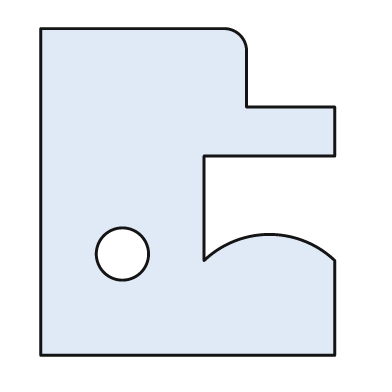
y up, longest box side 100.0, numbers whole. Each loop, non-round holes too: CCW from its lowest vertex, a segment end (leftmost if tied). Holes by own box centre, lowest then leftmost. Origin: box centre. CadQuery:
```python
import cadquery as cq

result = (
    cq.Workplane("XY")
    .moveTo(-45.0, -50.0)
    .lineTo(45.0, -50.0)
    .lineTo(45.0, -21.0)
    .threePointArc((25.0, -13.0), (5.0, -21.0))
    .lineTo(5.0, 11.0)
    .lineTo(45.0, 11.0)
    .lineTo(45.0, 26.0)
    .lineTo(18.0, 26.0)
    .lineTo(18.0, 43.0)
    .threePointArc((16.0, 48.0), (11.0, 50.0))
    .lineTo(-45.0, 50.0)
    .close()
    .moveTo(-20.0, -19.0)
    .circle(8.0)
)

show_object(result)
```